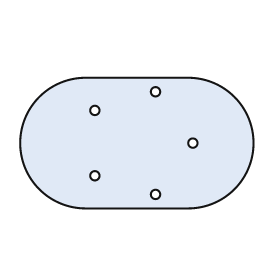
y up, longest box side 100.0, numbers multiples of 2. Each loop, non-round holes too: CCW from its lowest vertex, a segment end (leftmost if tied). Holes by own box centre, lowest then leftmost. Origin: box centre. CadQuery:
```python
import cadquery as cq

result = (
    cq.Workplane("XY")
    .moveTo(-22.0, -28.0)
    .lineTo(22.0, -28.0)
    .threePointArc((50.0, 0.0), (22.0, 28.0))
    .lineTo(-22.0, 28.0)
    .threePointArc((-50.0, 0.0), (-22.0, -28.0))
    .close()
    .moveTo(8.0, -22.0)
    .circle(2.0)
    .moveTo(-18.0, -14.0)
    .circle(2.0)
    .moveTo(24.0, 0.0)
    .circle(2.0)
    .moveTo(-18.0, 14.0)
    .circle(2.0)
    .moveTo(8.0, 22.0)
    .circle(2.0)
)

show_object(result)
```